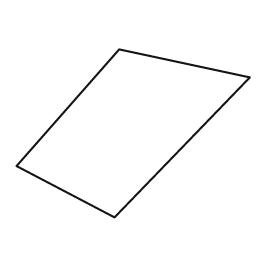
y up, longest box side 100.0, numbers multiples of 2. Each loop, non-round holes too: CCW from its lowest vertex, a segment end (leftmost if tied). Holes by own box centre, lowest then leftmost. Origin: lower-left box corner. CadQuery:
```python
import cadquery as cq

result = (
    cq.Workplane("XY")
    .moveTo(42.0, 0.0)
    .lineTo(100.0, 60.0)
    .lineTo(44.0, 72.0)
    .lineTo(0.0, 22.0)
    .close()
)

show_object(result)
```